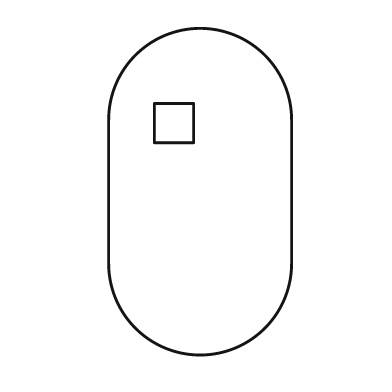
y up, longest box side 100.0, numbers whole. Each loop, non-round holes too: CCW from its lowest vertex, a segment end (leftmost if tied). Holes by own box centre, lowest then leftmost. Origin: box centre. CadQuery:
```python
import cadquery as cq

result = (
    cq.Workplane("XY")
    .moveTo(-28.0, -22.0)
    .threePointArc((0.0, -50.0), (28.0, -22.0))
    .lineTo(28.0, 22.0)
    .threePointArc((0.0, 50.0), (-28.0, 22.0))
    .close()
    .moveTo(-14.0, 15.0)
    .lineTo(-2.0, 15.0)
    .lineTo(-2.0, 27.0)
    .lineTo(-14.0, 27.0)
    .close()
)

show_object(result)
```